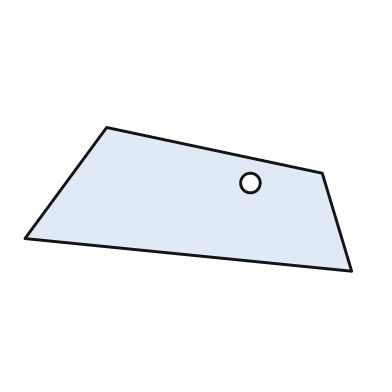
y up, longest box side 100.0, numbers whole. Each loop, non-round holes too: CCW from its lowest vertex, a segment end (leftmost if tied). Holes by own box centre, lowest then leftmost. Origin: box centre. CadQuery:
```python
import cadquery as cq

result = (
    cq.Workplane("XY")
    .moveTo(50.0, -22.0)
    .lineTo(41.0, 8.0)
    .lineTo(-25.0, 22.0)
    .lineTo(-50.0, -12.0)
    .close()
    .moveTo(19.0, 5.0)
    .circle(3.0)
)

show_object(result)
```